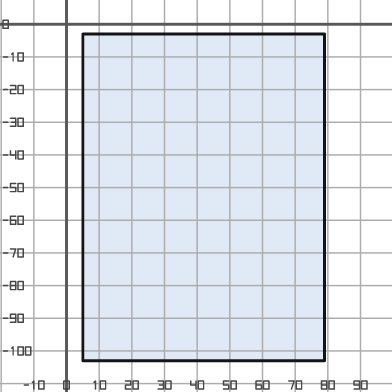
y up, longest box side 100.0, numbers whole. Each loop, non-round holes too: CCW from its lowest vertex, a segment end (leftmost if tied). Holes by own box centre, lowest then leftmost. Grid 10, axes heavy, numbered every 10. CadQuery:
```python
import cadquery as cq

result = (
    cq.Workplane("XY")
    .moveTo(5.0, -103.0)
    .lineTo(79.0, -103.0)
    .lineTo(79.0, -3.0)
    .lineTo(5.0, -3.0)
    .close()
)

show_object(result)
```